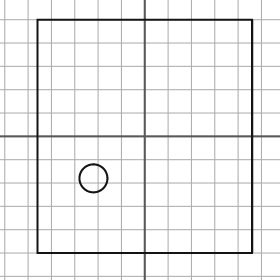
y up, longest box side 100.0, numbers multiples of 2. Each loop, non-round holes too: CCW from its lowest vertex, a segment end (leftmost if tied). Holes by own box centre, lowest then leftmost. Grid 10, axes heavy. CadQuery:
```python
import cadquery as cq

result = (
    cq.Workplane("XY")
    .moveTo(-46.0, -50.0)
    .lineTo(46.0, -50.0)
    .lineTo(46.0, 50.0)
    .lineTo(-46.0, 50.0)
    .close()
    .moveTo(-22.0, -18.0)
    .circle(6.0)
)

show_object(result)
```